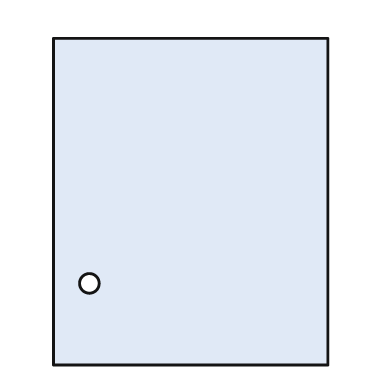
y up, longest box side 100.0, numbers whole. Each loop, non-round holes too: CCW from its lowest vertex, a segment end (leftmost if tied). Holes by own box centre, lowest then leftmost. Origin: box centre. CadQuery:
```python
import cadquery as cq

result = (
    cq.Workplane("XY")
    .moveTo(-42.0, -50.0)
    .lineTo(42.0, -50.0)
    .lineTo(42.0, 50.0)
    .lineTo(-42.0, 50.0)
    .close()
    .moveTo(-31.0, -25.0)
    .circle(3.0)
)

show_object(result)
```